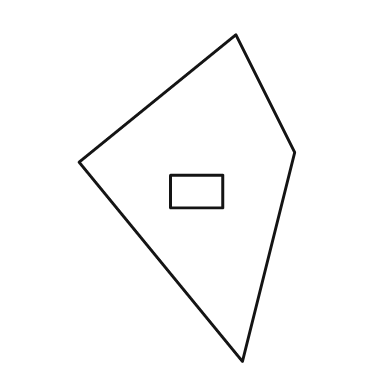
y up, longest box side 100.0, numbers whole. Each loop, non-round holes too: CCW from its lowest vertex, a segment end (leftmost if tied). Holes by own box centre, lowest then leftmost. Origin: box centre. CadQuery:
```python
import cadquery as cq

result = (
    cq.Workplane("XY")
    .moveTo(17.0, -50.0)
    .lineTo(33.0, 14.0)
    .lineTo(15.0, 50.0)
    .lineTo(-33.0, 11.0)
    .close()
    .moveTo(-5.0, -3.0)
    .lineTo(11.0, -3.0)
    .lineTo(11.0, 7.0)
    .lineTo(-5.0, 7.0)
    .close()
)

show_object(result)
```